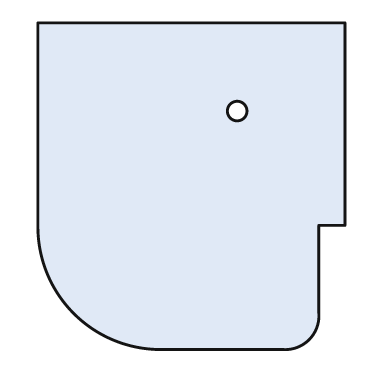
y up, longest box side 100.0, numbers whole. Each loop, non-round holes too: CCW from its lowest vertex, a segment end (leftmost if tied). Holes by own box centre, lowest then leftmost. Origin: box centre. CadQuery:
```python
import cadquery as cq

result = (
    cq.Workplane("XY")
    .moveTo(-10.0, -50.0)
    .lineTo(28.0, -50.0)
    .threePointArc((36.0, -47.0), (39.0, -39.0))
    .lineTo(39.0, -12.0)
    .lineTo(47.0, -12.0)
    .lineTo(47.0, 50.0)
    .lineTo(-47.0, 50.0)
    .lineTo(-47.0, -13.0)
    .threePointArc((-36.0, -39.0), (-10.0, -50.0))
    .close()
    .moveTo(14.0, 23.0)
    .circle(3.0)
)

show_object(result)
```